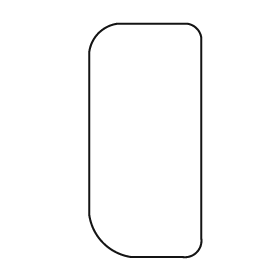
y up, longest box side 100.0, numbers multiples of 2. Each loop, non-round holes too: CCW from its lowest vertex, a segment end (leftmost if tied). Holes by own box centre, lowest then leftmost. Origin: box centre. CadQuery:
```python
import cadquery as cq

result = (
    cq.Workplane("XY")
    .moveTo(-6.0, -50.0)
    .lineTo(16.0, -50.0)
    .threePointArc((22.0, -48.0), (24.0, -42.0))
    .lineTo(24.0, 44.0)
    .threePointArc((22.0, 48.0), (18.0, 50.0))
    .lineTo(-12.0, 50.0)
    .threePointArc((-20.0, 46.0), (-24.0, 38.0))
    .lineTo(-24.0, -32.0)
    .threePointArc((-18.0, -44.0), (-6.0, -50.0))
    .close()
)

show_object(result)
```